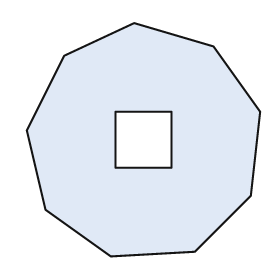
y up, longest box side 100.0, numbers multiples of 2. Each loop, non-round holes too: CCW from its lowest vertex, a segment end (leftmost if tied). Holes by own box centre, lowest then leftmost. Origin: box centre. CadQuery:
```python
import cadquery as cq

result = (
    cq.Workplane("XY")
    .moveTo(-14.0, -50.0)
    .lineTo(22.0, -48.0)
    .lineTo(46.0, -24.0)
    .lineTo(50.0, 12.0)
    .lineTo(30.0, 40.0)
    .lineTo(-4.0, 50.0)
    .lineTo(-34.0, 36.0)
    .lineTo(-50.0, 4.0)
    .lineTo(-42.0, -30.0)
    .close()
    .moveTo(-12.0, -12.0)
    .lineTo(12.0, -12.0)
    .lineTo(12.0, 12.0)
    .lineTo(-12.0, 12.0)
    .close()
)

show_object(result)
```